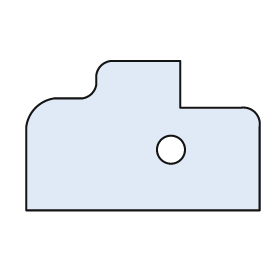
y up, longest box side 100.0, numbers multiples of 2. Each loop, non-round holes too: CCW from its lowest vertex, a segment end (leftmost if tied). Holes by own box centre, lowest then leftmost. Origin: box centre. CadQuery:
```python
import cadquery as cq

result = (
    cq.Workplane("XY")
    .moveTo(-50.0, -32.0)
    .lineTo(50.0, -32.0)
    .lineTo(50.0, 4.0)
    .threePointArc((48.0, 10.0), (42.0, 12.0))
    .lineTo(16.0, 12.0)
    .lineTo(16.0, 32.0)
    .lineTo(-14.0, 32.0)
    .threePointArc((-18.0, 30.0), (-20.0, 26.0))
    .lineTo(-20.0, 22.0)
    .threePointArc((-22.0, 18.0), (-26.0, 16.0))
    .lineTo(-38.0, 16.0)
    .threePointArc((-46.0, 12.0), (-50.0, 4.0))
    .close()
    .moveTo(12.0, -6.0)
    .circle(6.0)
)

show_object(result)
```